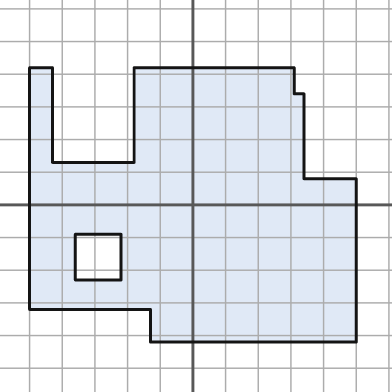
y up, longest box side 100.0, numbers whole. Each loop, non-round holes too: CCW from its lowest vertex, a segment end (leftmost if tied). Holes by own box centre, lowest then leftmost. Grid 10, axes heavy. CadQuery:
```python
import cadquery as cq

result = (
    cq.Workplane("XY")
    .moveTo(-13.0, -42.0)
    .lineTo(50.0, -42.0)
    .lineTo(50.0, 8.0)
    .lineTo(34.0, 8.0)
    .lineTo(34.0, 34.0)
    .lineTo(31.0, 34.0)
    .lineTo(31.0, 42.0)
    .lineTo(-18.0, 42.0)
    .lineTo(-18.0, 13.0)
    .lineTo(-43.0, 13.0)
    .lineTo(-43.0, 42.0)
    .lineTo(-50.0, 42.0)
    .lineTo(-50.0, -32.0)
    .lineTo(-13.0, -32.0)
    .close()
    .moveTo(-36.0, -23.0)
    .lineTo(-22.0, -23.0)
    .lineTo(-22.0, -9.0)
    .lineTo(-36.0, -9.0)
    .close()
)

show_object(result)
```